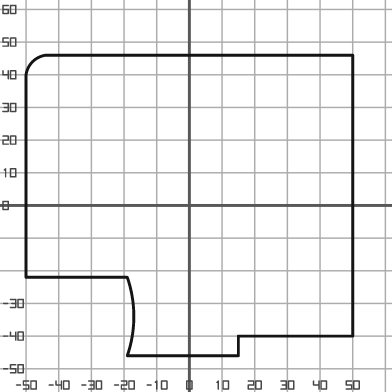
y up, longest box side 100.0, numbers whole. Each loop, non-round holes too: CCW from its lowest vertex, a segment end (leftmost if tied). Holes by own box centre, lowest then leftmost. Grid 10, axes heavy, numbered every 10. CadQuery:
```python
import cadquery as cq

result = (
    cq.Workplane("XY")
    .moveTo(-19.0, -46.0)
    .lineTo(15.0, -46.0)
    .lineTo(15.0, -40.0)
    .lineTo(50.0, -40.0)
    .lineTo(50.0, 46.0)
    .lineTo(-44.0, 46.0)
    .threePointArc((-48.0, 44.0), (-50.0, 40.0))
    .lineTo(-50.0, -22.0)
    .lineTo(-19.0, -22.0)
    .threePointArc((-17.0, -34.0), (-19.0, -46.0))
    .close()
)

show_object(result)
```